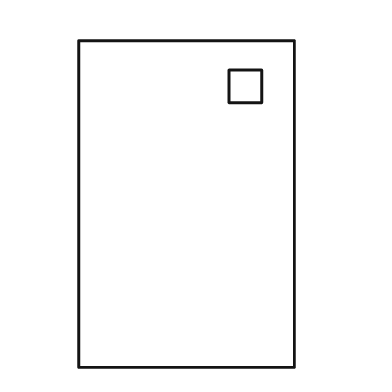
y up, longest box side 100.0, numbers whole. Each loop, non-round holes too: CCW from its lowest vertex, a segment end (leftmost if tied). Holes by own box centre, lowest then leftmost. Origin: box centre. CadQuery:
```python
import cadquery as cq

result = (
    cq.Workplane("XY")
    .moveTo(-33.0, -50.0)
    .lineTo(33.0, -50.0)
    .lineTo(33.0, 50.0)
    .lineTo(-33.0, 50.0)
    .close()
    .moveTo(13.0, 31.0)
    .lineTo(23.0, 31.0)
    .lineTo(23.0, 41.0)
    .lineTo(13.0, 41.0)
    .close()
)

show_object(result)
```